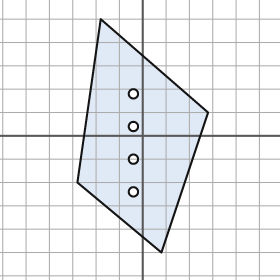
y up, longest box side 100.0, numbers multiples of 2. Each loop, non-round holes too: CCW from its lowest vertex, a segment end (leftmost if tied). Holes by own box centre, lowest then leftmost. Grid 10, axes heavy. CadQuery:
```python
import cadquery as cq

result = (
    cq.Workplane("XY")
    .moveTo(8.0, -50.0)
    .lineTo(28.0, 10.0)
    .lineTo(-18.0, 50.0)
    .lineTo(-28.0, -20.0)
    .close()
    .moveTo(-4.0, -24.0)
    .circle(2.0)
    .moveTo(-4.0, -10.0)
    .circle(2.0)
    .moveTo(-4.0, 4.0)
    .circle(2.0)
    .moveTo(-4.0, 18.0)
    .circle(2.0)
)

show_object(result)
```